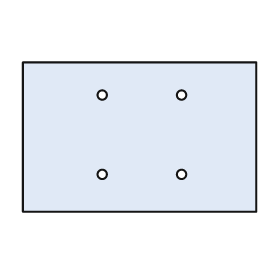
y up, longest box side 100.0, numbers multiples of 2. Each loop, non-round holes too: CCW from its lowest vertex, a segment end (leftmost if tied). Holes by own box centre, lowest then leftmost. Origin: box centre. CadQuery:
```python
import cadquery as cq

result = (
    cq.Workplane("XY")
    .moveTo(-50.0, -32.0)
    .lineTo(50.0, -32.0)
    .lineTo(50.0, 32.0)
    .lineTo(-50.0, 32.0)
    .close()
    .moveTo(-16.0, -16.0)
    .circle(2.0)
    .moveTo(18.0, -16.0)
    .circle(2.0)
    .moveTo(-16.0, 18.0)
    .circle(2.0)
    .moveTo(18.0, 18.0)
    .circle(2.0)
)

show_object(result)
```